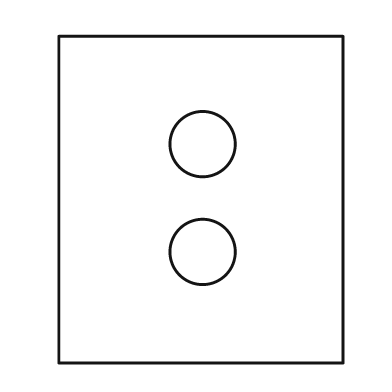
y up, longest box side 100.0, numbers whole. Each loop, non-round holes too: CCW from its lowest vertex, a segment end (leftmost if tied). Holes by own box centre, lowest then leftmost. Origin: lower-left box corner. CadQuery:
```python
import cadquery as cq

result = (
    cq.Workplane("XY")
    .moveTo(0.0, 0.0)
    .lineTo(87.0, 0.0)
    .lineTo(87.0, 100.0)
    .lineTo(0.0, 100.0)
    .close()
    .moveTo(44.0, 34.0)
    .circle(10.0)
    .moveTo(44.0, 67.0)
    .circle(10.0)
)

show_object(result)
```